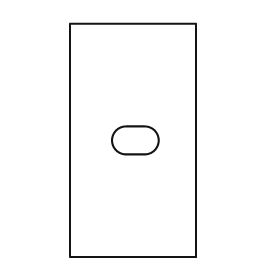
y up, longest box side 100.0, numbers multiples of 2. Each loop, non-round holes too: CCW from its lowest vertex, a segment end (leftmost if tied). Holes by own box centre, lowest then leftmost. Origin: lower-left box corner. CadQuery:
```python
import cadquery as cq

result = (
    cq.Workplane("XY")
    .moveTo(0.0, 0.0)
    .lineTo(54.0, 0.0)
    .lineTo(54.0, 100.0)
    .lineTo(0.0, 100.0)
    .close()
    .moveTo(24.0, 44.0)
    .lineTo(32.0, 44.0)
    .threePointArc((38.0, 50.0), (32.0, 56.0))
    .lineTo(24.0, 56.0)
    .threePointArc((18.0, 50.0), (24.0, 44.0))
    .close()
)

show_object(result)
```